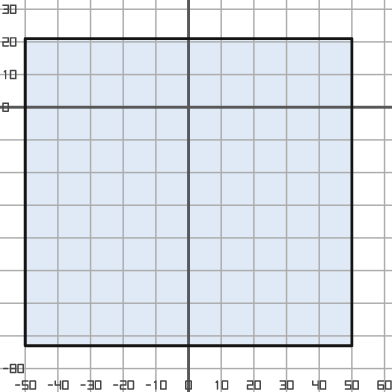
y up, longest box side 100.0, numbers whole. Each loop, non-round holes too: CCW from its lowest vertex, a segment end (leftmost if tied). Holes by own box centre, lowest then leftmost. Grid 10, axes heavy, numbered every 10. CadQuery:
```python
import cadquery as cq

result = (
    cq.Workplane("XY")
    .moveTo(-50.0, -73.0)
    .lineTo(50.0, -73.0)
    .lineTo(50.0, 21.0)
    .lineTo(-50.0, 21.0)
    .close()
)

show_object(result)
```